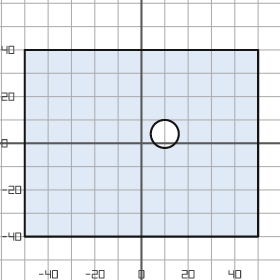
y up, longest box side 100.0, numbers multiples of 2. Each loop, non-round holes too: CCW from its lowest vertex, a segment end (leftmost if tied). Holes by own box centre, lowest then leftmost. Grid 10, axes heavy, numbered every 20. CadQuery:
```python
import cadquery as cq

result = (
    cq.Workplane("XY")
    .moveTo(-50.0, -40.0)
    .lineTo(50.0, -40.0)
    .lineTo(50.0, 40.0)
    .lineTo(-50.0, 40.0)
    .close()
    .moveTo(10.0, 4.0)
    .circle(6.0)
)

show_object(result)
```